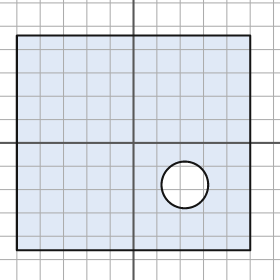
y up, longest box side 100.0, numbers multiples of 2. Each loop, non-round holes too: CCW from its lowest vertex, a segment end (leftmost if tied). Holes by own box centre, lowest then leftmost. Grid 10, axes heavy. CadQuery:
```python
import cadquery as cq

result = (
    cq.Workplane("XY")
    .moveTo(-50.0, -46.0)
    .lineTo(50.0, -46.0)
    .lineTo(50.0, 46.0)
    .lineTo(-50.0, 46.0)
    .close()
    .moveTo(22.0, -18.0)
    .circle(10.0)
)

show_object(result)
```